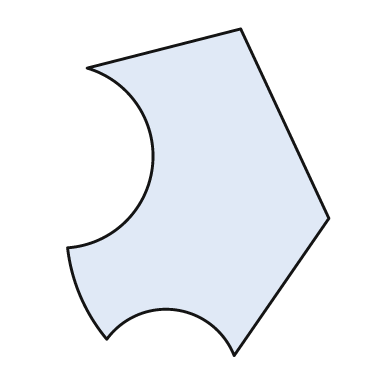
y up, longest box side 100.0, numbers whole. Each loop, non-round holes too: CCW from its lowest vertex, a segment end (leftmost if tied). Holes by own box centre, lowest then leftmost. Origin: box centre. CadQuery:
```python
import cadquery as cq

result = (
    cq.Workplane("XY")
    .moveTo(11.0, -50.0)
    .lineTo(40.0, -8.0)
    .lineTo(13.0, 50.0)
    .lineTo(-34.0, 38.0)
    .threePointArc((-14.0, 8.0), (-40.0, -17.0))
    .threePointArc((-36.0, -32.0), (-28.0, -45.0))
    .threePointArc((-7.0, -36.0), (11.0, -50.0))
    .close()
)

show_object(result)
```